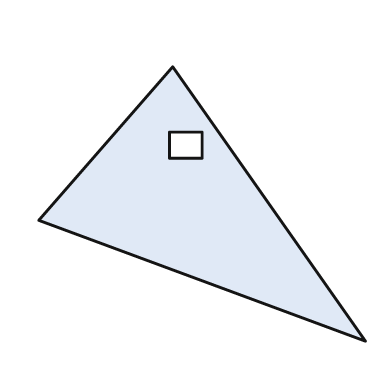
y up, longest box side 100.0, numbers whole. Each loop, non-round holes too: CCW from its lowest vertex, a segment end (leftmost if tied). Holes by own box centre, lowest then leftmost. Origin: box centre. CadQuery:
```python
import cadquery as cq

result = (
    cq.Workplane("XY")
    .moveTo(50.0, -42.0)
    .lineTo(-9.0, 42.0)
    .lineTo(-50.0, -5.0)
    .close()
    .moveTo(-10.0, 14.0)
    .lineTo(0.0, 14.0)
    .lineTo(0.0, 22.0)
    .lineTo(-10.0, 22.0)
    .close()
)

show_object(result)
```